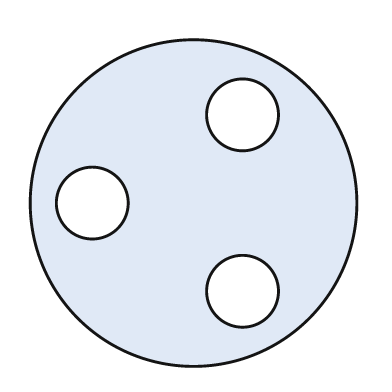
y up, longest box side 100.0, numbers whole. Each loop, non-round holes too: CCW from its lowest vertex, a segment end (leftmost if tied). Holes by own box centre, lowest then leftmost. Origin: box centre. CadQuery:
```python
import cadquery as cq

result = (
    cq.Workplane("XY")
    .moveTo(0.0, 0.0)
    .circle(50.0)
    .moveTo(15.0, -27.0)
    .circle(11.0)
    .moveTo(-31.0, 0.0)
    .circle(11.0)
    .moveTo(15.0, 27.0)
    .circle(11.0)
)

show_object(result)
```